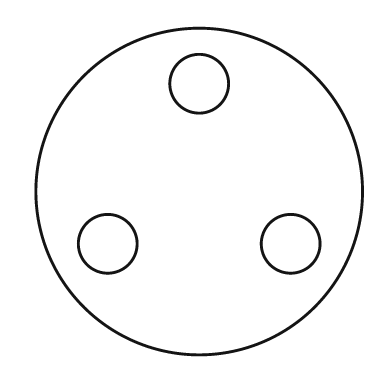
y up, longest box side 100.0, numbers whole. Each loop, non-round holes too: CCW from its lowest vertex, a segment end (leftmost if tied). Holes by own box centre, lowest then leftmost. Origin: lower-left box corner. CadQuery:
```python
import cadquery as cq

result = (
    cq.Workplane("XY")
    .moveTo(50.0, 50.0)
    .circle(50.0)
    .moveTo(22.0, 34.0)
    .circle(9.0)
    .moveTo(78.0, 34.0)
    .circle(9.0)
    .moveTo(50.0, 83.0)
    .circle(9.0)
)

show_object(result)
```